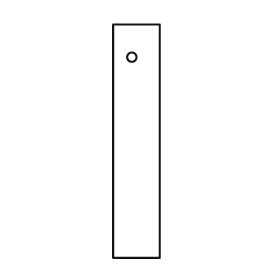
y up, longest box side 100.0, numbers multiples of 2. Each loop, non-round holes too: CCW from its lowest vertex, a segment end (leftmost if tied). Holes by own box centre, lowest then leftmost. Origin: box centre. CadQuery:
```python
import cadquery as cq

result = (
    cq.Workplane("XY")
    .moveTo(-10.0, -50.0)
    .lineTo(10.0, -50.0)
    .lineTo(10.0, 50.0)
    .lineTo(-10.0, 50.0)
    .close()
    .moveTo(-2.0, 36.0)
    .circle(2.0)
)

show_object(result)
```